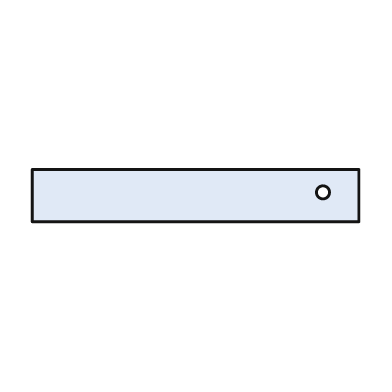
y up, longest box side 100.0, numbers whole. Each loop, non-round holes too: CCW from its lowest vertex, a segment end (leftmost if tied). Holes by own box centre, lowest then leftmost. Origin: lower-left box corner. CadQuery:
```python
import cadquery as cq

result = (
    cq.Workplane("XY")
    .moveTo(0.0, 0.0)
    .lineTo(100.0, 0.0)
    .lineTo(100.0, 16.0)
    .lineTo(0.0, 16.0)
    .close()
    .moveTo(89.0, 9.0)
    .circle(2.0)
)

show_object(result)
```